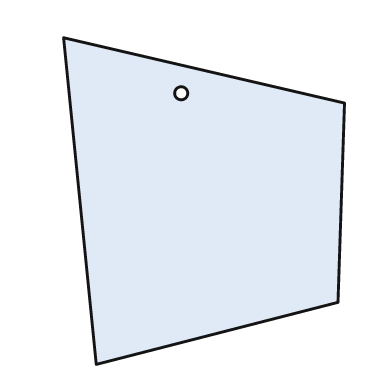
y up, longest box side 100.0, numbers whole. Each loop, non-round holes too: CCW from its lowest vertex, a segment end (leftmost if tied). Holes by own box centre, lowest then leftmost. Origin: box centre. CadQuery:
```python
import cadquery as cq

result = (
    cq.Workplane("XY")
    .moveTo(-33.0, -50.0)
    .lineTo(41.0, -31.0)
    .lineTo(43.0, 30.0)
    .lineTo(-43.0, 50.0)
    .close()
    .moveTo(-7.0, 33.0)
    .circle(2.0)
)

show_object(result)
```